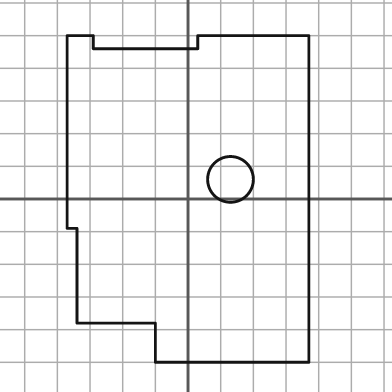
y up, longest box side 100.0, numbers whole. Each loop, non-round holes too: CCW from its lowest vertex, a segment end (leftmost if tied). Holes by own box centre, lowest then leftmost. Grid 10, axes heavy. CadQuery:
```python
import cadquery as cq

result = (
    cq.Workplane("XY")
    .moveTo(-10.0, -50.0)
    .lineTo(37.0, -50.0)
    .lineTo(37.0, 50.0)
    .lineTo(3.0, 50.0)
    .lineTo(3.0, 46.0)
    .lineTo(-29.0, 46.0)
    .lineTo(-29.0, 50.0)
    .lineTo(-37.0, 50.0)
    .lineTo(-37.0, -9.0)
    .lineTo(-34.0, -9.0)
    .lineTo(-34.0, -38.0)
    .lineTo(-10.0, -38.0)
    .close()
    .moveTo(13.0, 6.0)
    .circle(7.0)
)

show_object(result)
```